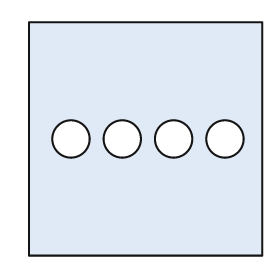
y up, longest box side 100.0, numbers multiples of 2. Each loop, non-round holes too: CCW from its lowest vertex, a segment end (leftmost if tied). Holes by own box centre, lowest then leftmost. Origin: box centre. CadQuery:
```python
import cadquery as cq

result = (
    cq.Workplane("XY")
    .moveTo(-50.0, -50.0)
    .lineTo(50.0, -50.0)
    .lineTo(50.0, 50.0)
    .lineTo(-50.0, 50.0)
    .close()
    .moveTo(-32.0, 0.0)
    .circle(8.0)
    .moveTo(-10.0, 0.0)
    .circle(8.0)
    .moveTo(12.0, 0.0)
    .circle(8.0)
    .moveTo(34.0, 0.0)
    .circle(8.0)
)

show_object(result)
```